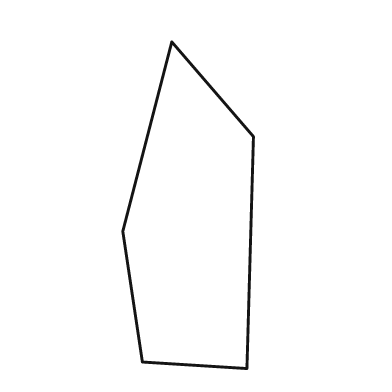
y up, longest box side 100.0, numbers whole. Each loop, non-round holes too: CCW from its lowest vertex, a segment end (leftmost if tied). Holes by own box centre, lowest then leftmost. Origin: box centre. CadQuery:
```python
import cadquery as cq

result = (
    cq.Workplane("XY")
    .moveTo(18.0, -50.0)
    .lineTo(20.0, 21.0)
    .lineTo(-5.0, 50.0)
    .lineTo(-20.0, -8.0)
    .lineTo(-14.0, -48.0)
    .close()
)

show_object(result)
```